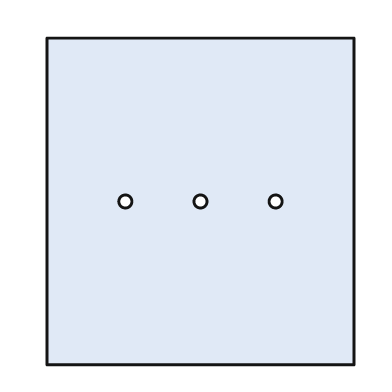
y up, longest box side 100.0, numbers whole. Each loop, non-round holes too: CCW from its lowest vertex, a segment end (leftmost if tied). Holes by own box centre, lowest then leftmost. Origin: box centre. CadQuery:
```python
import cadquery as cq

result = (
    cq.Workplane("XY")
    .moveTo(-47.0, -50.0)
    .lineTo(47.0, -50.0)
    .lineTo(47.0, 50.0)
    .lineTo(-47.0, 50.0)
    .close()
    .moveTo(-23.0, 0.0)
    .circle(2.0)
    .moveTo(0.0, 0.0)
    .circle(2.0)
    .moveTo(23.0, 0.0)
    .circle(2.0)
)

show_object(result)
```